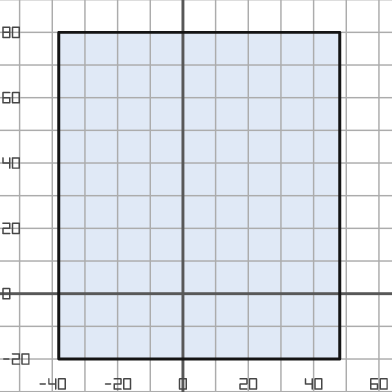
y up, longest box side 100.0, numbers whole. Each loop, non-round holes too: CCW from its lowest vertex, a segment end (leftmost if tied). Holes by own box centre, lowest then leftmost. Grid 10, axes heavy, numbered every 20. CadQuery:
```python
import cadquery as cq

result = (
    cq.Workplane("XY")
    .moveTo(-38.0, -20.0)
    .lineTo(48.0, -20.0)
    .lineTo(48.0, 80.0)
    .lineTo(-38.0, 80.0)
    .close()
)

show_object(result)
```